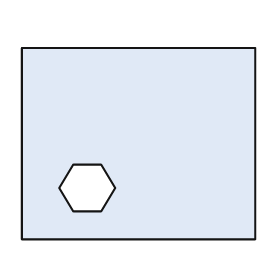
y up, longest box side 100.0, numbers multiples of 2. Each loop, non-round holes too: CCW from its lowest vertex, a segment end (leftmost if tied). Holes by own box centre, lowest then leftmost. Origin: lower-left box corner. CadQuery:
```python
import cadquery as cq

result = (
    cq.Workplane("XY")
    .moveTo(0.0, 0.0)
    .lineTo(100.0, 0.0)
    .lineTo(100.0, 82.0)
    .lineTo(0.0, 82.0)
    .close()
    .moveTo(22.0, 12.0)
    .lineTo(34.0, 12.0)
    .lineTo(40.0, 22.0)
    .lineTo(34.0, 32.0)
    .lineTo(22.0, 32.0)
    .lineTo(16.0, 22.0)
    .close()
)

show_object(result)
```